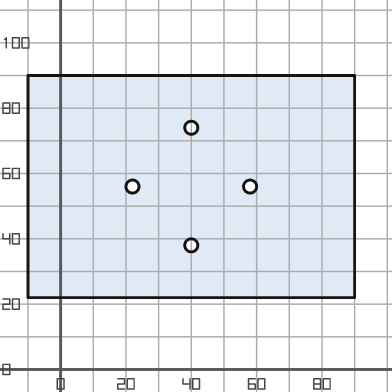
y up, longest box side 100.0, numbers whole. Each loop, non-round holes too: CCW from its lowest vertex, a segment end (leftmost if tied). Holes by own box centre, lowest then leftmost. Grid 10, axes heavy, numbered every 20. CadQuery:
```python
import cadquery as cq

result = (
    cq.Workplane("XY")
    .moveTo(-10.0, 22.0)
    .lineTo(90.0, 22.0)
    .lineTo(90.0, 90.0)
    .lineTo(-10.0, 90.0)
    .close()
    .moveTo(40.0, 38.0)
    .circle(2.0)
    .moveTo(22.0, 56.0)
    .circle(2.0)
    .moveTo(58.0, 56.0)
    .circle(2.0)
    .moveTo(40.0, 74.0)
    .circle(2.0)
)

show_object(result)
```